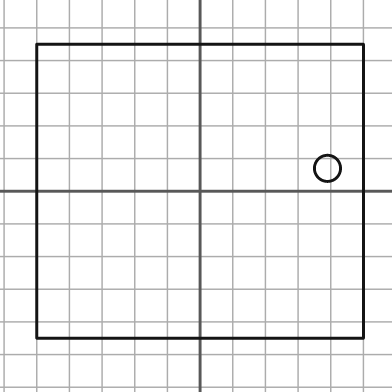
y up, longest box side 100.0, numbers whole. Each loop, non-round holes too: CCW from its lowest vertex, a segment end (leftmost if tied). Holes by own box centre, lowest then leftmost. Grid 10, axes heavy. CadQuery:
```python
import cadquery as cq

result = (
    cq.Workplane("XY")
    .moveTo(-50.0, -45.0)
    .lineTo(50.0, -45.0)
    .lineTo(50.0, 45.0)
    .lineTo(-50.0, 45.0)
    .close()
    .moveTo(39.0, 7.0)
    .circle(4.0)
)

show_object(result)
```